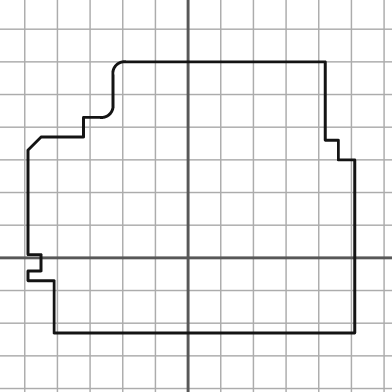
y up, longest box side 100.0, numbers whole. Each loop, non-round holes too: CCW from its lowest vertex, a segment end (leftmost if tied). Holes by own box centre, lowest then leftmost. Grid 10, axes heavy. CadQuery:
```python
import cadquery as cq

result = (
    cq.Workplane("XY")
    .moveTo(-41.0, -23.0)
    .lineTo(51.0, -23.0)
    .lineTo(51.0, 30.0)
    .lineTo(46.0, 30.0)
    .lineTo(46.0, 36.0)
    .lineTo(42.0, 36.0)
    .lineTo(42.0, 60.0)
    .lineTo(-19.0, 60.0)
    .threePointArc((-22.0, 59.0), (-23.0, 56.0))
    .lineTo(-23.0, 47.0)
    .threePointArc((-24.0, 44.0), (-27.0, 43.0))
    .lineTo(-32.0, 43.0)
    .lineTo(-32.0, 37.0)
    .lineTo(-45.0, 37.0)
    .lineTo(-49.0, 33.0)
    .lineTo(-49.0, 1.0)
    .lineTo(-45.0, 1.0)
    .lineTo(-45.0, -4.0)
    .lineTo(-49.0, -4.0)
    .lineTo(-49.0, -7.0)
    .lineTo(-41.0, -7.0)
    .close()
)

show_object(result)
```